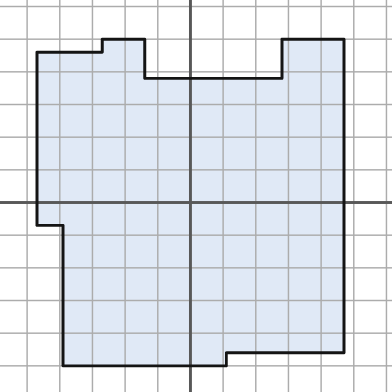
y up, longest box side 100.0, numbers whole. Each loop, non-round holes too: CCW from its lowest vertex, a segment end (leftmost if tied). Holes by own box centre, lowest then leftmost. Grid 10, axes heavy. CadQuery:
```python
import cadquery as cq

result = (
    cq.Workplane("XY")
    .moveTo(-39.0, -50.0)
    .lineTo(11.0, -50.0)
    .lineTo(11.0, -46.0)
    .lineTo(47.0, -46.0)
    .lineTo(47.0, 50.0)
    .lineTo(28.0, 50.0)
    .lineTo(28.0, 38.0)
    .lineTo(-14.0, 38.0)
    .lineTo(-14.0, 50.0)
    .lineTo(-27.0, 50.0)
    .lineTo(-27.0, 46.0)
    .lineTo(-47.0, 46.0)
    .lineTo(-47.0, -7.0)
    .lineTo(-39.0, -7.0)
    .close()
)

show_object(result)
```